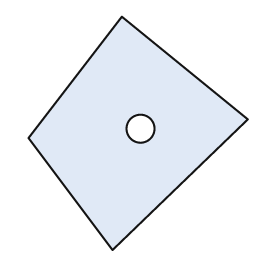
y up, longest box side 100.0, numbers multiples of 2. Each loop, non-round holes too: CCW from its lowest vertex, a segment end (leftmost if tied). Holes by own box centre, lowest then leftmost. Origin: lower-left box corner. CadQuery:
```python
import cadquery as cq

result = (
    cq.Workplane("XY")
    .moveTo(36.0, 0.0)
    .lineTo(94.0, 56.0)
    .lineTo(40.0, 100.0)
    .lineTo(0.0, 48.0)
    .close()
    .moveTo(48.0, 52.0)
    .circle(6.0)
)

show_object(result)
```